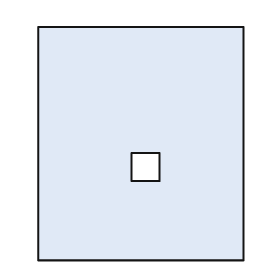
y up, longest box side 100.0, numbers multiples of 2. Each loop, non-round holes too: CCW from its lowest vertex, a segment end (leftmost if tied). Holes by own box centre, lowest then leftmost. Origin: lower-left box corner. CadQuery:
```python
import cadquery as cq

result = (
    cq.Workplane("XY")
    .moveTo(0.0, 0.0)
    .lineTo(88.0, 0.0)
    .lineTo(88.0, 100.0)
    .lineTo(0.0, 100.0)
    .close()
    .moveTo(40.0, 34.0)
    .lineTo(52.0, 34.0)
    .lineTo(52.0, 46.0)
    .lineTo(40.0, 46.0)
    .close()
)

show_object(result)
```